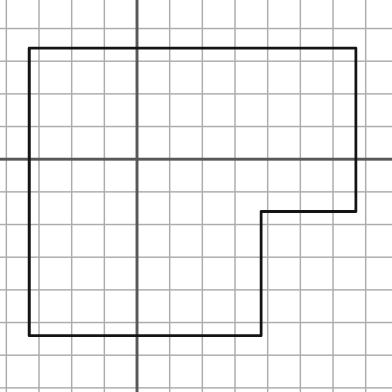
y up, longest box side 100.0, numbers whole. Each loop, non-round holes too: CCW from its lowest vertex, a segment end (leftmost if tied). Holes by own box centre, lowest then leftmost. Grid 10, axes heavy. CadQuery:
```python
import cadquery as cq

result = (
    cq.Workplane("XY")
    .moveTo(-33.0, -54.0)
    .lineTo(38.0, -54.0)
    .lineTo(38.0, -16.0)
    .lineTo(67.0, -16.0)
    .lineTo(67.0, 34.0)
    .lineTo(-33.0, 34.0)
    .close()
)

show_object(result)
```